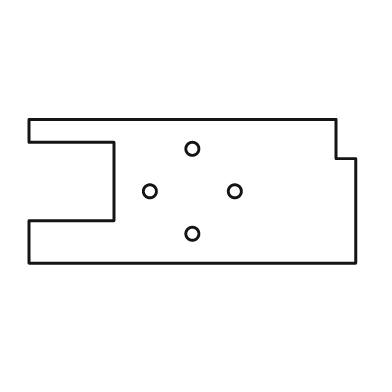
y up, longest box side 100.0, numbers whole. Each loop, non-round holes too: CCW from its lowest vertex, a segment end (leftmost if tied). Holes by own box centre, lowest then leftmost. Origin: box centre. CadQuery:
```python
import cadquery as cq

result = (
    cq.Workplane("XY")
    .moveTo(-50.0, -22.0)
    .lineTo(50.0, -22.0)
    .lineTo(50.0, 10.0)
    .lineTo(44.0, 10.0)
    .lineTo(44.0, 22.0)
    .lineTo(-50.0, 22.0)
    .lineTo(-50.0, 15.0)
    .lineTo(-24.0, 15.0)
    .lineTo(-24.0, -9.0)
    .lineTo(-50.0, -9.0)
    .close()
    .moveTo(0.0, -13.0)
    .circle(2.0)
    .moveTo(-13.0, 0.0)
    .circle(2.0)
    .moveTo(13.0, 0.0)
    .circle(2.0)
    .moveTo(0.0, 13.0)
    .circle(2.0)
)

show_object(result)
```